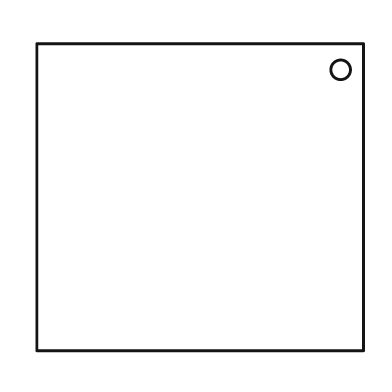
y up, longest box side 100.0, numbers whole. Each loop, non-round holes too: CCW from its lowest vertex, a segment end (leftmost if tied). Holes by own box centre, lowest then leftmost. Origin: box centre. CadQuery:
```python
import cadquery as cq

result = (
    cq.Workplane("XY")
    .moveTo(-50.0, -47.0)
    .lineTo(50.0, -47.0)
    .lineTo(50.0, 47.0)
    .lineTo(-50.0, 47.0)
    .close()
    .moveTo(43.0, 39.0)
    .circle(3.0)
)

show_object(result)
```